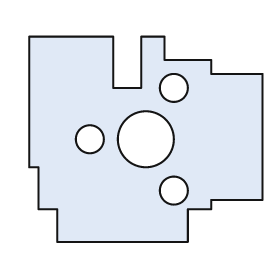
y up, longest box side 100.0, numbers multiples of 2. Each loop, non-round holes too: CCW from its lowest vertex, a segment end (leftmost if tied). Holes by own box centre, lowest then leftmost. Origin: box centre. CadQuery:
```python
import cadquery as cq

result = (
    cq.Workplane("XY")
    .moveTo(-38.0, -44.0)
    .lineTo(18.0, -44.0)
    .lineTo(18.0, -30.0)
    .lineTo(28.0, -30.0)
    .lineTo(28.0, -26.0)
    .lineTo(50.0, -26.0)
    .lineTo(50.0, 28.0)
    .lineTo(28.0, 28.0)
    .lineTo(28.0, 34.0)
    .lineTo(8.0, 34.0)
    .lineTo(8.0, 44.0)
    .lineTo(-2.0, 44.0)
    .lineTo(-2.0, 22.0)
    .lineTo(-14.0, 22.0)
    .lineTo(-14.0, 44.0)
    .lineTo(-50.0, 44.0)
    .lineTo(-50.0, -12.0)
    .lineTo(-46.0, -12.0)
    .lineTo(-46.0, -30.0)
    .lineTo(-38.0, -30.0)
    .close()
    .moveTo(12.0, -22.0)
    .circle(6.0)
    .moveTo(-24.0, 0.0)
    .circle(6.0)
    .moveTo(0.0, 0.0)
    .circle(12.0)
    .moveTo(12.0, 22.0)
    .circle(6.0)
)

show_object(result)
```